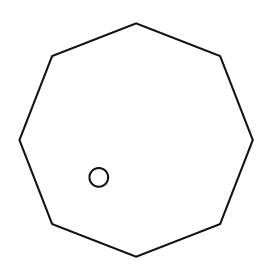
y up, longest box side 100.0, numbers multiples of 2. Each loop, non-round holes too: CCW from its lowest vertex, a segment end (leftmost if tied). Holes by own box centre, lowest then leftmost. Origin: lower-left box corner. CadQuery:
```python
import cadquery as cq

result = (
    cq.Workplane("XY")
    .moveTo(50.0, 0.0)
    .lineTo(86.0, 14.0)
    .lineTo(100.0, 50.0)
    .lineTo(86.0, 86.0)
    .lineTo(50.0, 100.0)
    .lineTo(14.0, 86.0)
    .lineTo(0.0, 50.0)
    .lineTo(14.0, 14.0)
    .close()
    .moveTo(34.0, 34.0)
    .circle(4.0)
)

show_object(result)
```